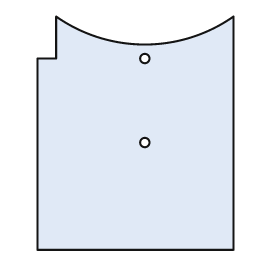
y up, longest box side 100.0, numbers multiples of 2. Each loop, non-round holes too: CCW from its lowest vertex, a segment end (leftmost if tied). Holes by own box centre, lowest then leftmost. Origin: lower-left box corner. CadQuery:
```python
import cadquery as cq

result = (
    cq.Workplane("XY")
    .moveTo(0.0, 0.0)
    .lineTo(84.0, 0.0)
    .lineTo(84.0, 100.0)
    .threePointArc((46.0, 88.0), (8.0, 100.0))
    .lineTo(8.0, 82.0)
    .lineTo(0.0, 82.0)
    .close()
    .moveTo(46.0, 46.0)
    .circle(2.0)
    .moveTo(46.0, 82.0)
    .circle(2.0)
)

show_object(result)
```